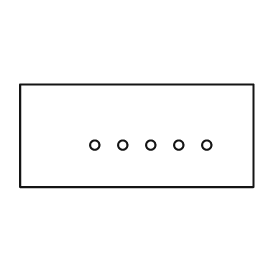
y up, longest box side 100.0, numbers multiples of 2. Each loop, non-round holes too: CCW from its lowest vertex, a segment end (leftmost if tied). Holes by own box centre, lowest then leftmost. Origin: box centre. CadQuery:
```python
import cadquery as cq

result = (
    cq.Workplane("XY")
    .moveTo(-50.0, -22.0)
    .lineTo(50.0, -22.0)
    .lineTo(50.0, 22.0)
    .lineTo(-50.0, 22.0)
    .close()
    .moveTo(-18.0, -4.0)
    .circle(2.0)
    .moveTo(-6.0, -4.0)
    .circle(2.0)
    .moveTo(6.0, -4.0)
    .circle(2.0)
    .moveTo(18.0, -4.0)
    .circle(2.0)
    .moveTo(30.0, -4.0)
    .circle(2.0)
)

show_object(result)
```